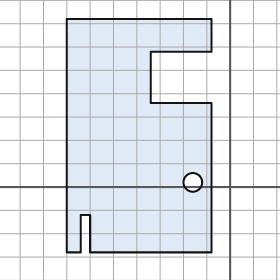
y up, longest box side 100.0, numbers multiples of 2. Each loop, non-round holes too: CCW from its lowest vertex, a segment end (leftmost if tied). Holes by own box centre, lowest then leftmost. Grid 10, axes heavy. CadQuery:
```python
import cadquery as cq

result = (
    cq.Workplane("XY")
    .moveTo(-70.0, -28.0)
    .lineTo(-64.0, -28.0)
    .lineTo(-64.0, -12.0)
    .lineTo(-60.0, -12.0)
    .lineTo(-60.0, -28.0)
    .lineTo(-8.0, -28.0)
    .lineTo(-8.0, 36.0)
    .lineTo(-34.0, 36.0)
    .lineTo(-34.0, 58.0)
    .lineTo(-8.0, 58.0)
    .lineTo(-8.0, 72.0)
    .lineTo(-70.0, 72.0)
    .close()
    .moveTo(-16.0, 2.0)
    .circle(4.0)
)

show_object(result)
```